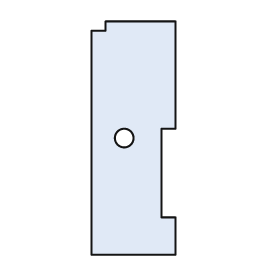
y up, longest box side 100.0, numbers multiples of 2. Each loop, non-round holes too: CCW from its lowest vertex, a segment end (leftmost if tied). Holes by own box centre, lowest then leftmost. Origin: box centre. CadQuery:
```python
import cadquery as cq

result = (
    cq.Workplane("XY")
    .moveTo(-18.0, -50.0)
    .lineTo(18.0, -50.0)
    .lineTo(18.0, -34.0)
    .lineTo(12.0, -34.0)
    .lineTo(12.0, 4.0)
    .lineTo(18.0, 4.0)
    .lineTo(18.0, 50.0)
    .lineTo(-12.0, 50.0)
    .lineTo(-12.0, 46.0)
    .lineTo(-18.0, 46.0)
    .close()
    .moveTo(-4.0, 0.0)
    .circle(4.0)
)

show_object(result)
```